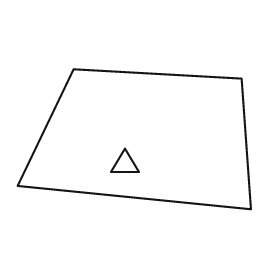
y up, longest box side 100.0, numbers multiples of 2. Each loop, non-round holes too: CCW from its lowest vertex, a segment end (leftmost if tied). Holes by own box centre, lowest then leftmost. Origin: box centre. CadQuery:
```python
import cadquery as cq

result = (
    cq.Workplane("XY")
    .moveTo(50.0, -30.0)
    .lineTo(46.0, 26.0)
    .lineTo(-26.0, 30.0)
    .lineTo(-50.0, -20.0)
    .close()
    .moveTo(-10.0, -14.0)
    .lineTo(2.0, -14.0)
    .lineTo(-4.0, -4.0)
    .close()
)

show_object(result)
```